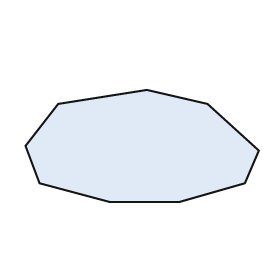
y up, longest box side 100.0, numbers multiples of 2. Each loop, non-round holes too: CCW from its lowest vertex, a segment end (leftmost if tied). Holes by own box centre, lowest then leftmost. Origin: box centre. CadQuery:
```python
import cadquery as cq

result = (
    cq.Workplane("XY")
    .moveTo(-14.0, -24.0)
    .lineTo(16.0, -24.0)
    .lineTo(44.0, -16.0)
    .lineTo(50.0, -2.0)
    .lineTo(28.0, 18.0)
    .lineTo(2.0, 24.0)
    .lineTo(-36.0, 18.0)
    .lineTo(-50.0, 0.0)
    .lineTo(-44.0, -16.0)
    .close()
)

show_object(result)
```